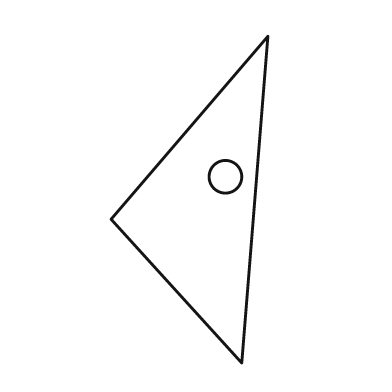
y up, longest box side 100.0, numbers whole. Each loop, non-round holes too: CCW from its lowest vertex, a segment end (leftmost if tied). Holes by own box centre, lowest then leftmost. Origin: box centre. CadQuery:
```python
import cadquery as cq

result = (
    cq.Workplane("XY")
    .moveTo(16.0, -50.0)
    .lineTo(24.0, 50.0)
    .lineTo(-24.0, -6.0)
    .close()
    .moveTo(11.0, 7.0)
    .circle(5.0)
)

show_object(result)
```